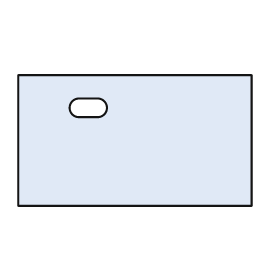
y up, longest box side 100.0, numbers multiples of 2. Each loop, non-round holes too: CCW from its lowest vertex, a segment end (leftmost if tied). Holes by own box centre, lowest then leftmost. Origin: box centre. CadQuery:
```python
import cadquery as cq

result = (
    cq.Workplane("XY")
    .moveTo(-50.0, -28.0)
    .lineTo(50.0, -28.0)
    .lineTo(50.0, 28.0)
    .lineTo(-50.0, 28.0)
    .close()
    .moveTo(-24.0, 10.0)
    .lineTo(-16.0, 10.0)
    .threePointArc((-12.0, 14.0), (-16.0, 18.0))
    .lineTo(-24.0, 18.0)
    .threePointArc((-28.0, 14.0), (-24.0, 10.0))
    .close()
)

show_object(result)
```